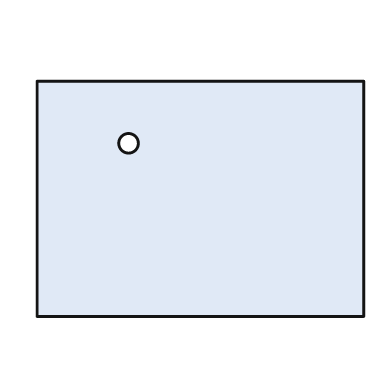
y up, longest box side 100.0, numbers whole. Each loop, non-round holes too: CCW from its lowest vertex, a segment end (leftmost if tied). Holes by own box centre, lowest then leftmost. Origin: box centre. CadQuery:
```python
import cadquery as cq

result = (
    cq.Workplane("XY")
    .moveTo(-50.0, -36.0)
    .lineTo(50.0, -36.0)
    .lineTo(50.0, 36.0)
    .lineTo(-50.0, 36.0)
    .close()
    .moveTo(-22.0, 17.0)
    .circle(3.0)
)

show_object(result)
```